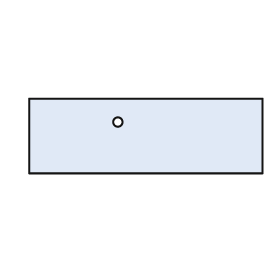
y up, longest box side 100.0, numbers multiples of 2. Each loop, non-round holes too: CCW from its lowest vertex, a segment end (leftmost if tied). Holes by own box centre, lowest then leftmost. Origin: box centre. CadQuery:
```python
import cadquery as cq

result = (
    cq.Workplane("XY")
    .moveTo(-50.0, -16.0)
    .lineTo(50.0, -16.0)
    .lineTo(50.0, 16.0)
    .lineTo(-50.0, 16.0)
    .close()
    .moveTo(-12.0, 6.0)
    .circle(2.0)
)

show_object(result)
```